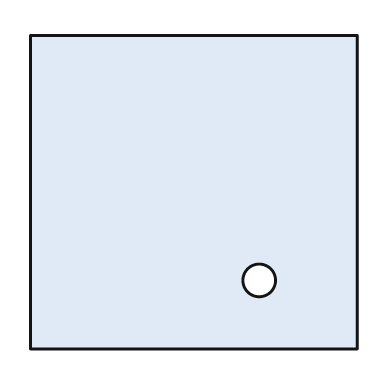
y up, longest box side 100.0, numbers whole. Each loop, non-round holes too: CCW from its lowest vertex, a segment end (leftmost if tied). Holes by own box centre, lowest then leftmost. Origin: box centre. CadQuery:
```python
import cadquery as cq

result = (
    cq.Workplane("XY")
    .moveTo(-50.0, -48.0)
    .lineTo(50.0, -48.0)
    .lineTo(50.0, 48.0)
    .lineTo(-50.0, 48.0)
    .close()
    .moveTo(20.0, -27.0)
    .circle(5.0)
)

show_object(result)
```